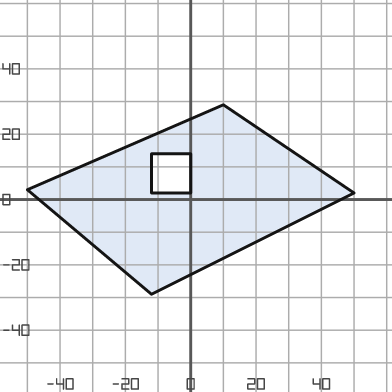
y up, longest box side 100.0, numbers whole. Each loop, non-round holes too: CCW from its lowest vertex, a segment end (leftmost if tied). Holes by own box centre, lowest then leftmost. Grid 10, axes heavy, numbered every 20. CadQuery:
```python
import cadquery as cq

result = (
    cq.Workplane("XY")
    .moveTo(-12.0, -29.0)
    .lineTo(50.0, 2.0)
    .lineTo(10.0, 29.0)
    .lineTo(-50.0, 3.0)
    .close()
    .moveTo(-12.0, 2.0)
    .lineTo(0.0, 2.0)
    .lineTo(0.0, 14.0)
    .lineTo(-12.0, 14.0)
    .close()
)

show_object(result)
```